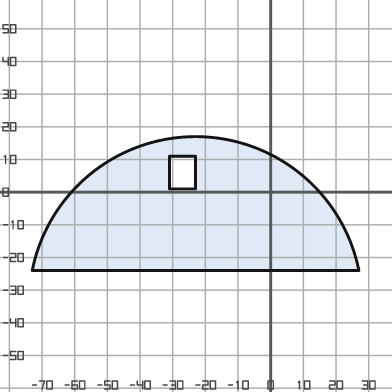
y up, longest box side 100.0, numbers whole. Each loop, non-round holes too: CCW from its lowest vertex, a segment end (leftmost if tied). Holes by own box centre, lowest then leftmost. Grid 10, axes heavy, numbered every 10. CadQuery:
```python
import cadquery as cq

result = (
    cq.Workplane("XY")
    .moveTo(-73.0, -24.0)
    .lineTo(27.0, -24.0)
    .threePointArc((-23.0, 17.0), (-73.0, -24.0))
    .close()
    .moveTo(-31.0, 1.0)
    .lineTo(-23.0, 1.0)
    .lineTo(-23.0, 11.0)
    .lineTo(-31.0, 11.0)
    .close()
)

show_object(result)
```